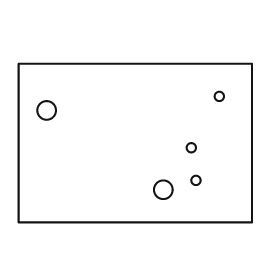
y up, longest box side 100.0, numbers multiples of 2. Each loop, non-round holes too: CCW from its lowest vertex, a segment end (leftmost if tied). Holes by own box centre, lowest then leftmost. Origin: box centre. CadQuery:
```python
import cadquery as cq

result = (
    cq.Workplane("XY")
    .moveTo(-50.0, -34.0)
    .lineTo(50.0, -34.0)
    .lineTo(50.0, 34.0)
    .lineTo(-50.0, 34.0)
    .close()
    .moveTo(12.0, -20.0)
    .circle(4.0)
    .moveTo(26.0, -16.0)
    .circle(2.0)
    .moveTo(24.0, -2.0)
    .circle(2.0)
    .moveTo(-38.0, 14.0)
    .circle(4.0)
    .moveTo(36.0, 20.0)
    .circle(2.0)
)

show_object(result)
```